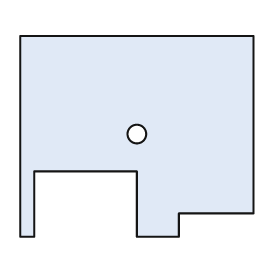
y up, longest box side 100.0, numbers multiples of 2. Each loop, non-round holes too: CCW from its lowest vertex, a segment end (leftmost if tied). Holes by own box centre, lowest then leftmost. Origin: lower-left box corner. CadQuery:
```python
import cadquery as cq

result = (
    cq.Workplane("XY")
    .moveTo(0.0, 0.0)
    .lineTo(6.0, 0.0)
    .lineTo(6.0, 28.0)
    .lineTo(50.0, 28.0)
    .lineTo(50.0, 0.0)
    .lineTo(68.0, 0.0)
    .lineTo(68.0, 10.0)
    .lineTo(100.0, 10.0)
    .lineTo(100.0, 86.0)
    .lineTo(0.0, 86.0)
    .close()
    .moveTo(50.0, 44.0)
    .circle(4.0)
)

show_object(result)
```